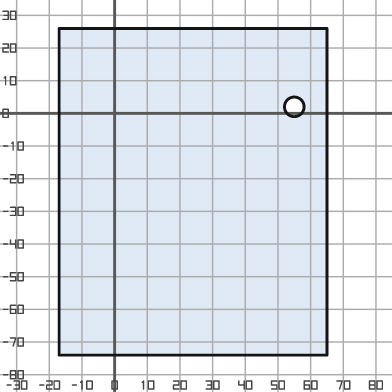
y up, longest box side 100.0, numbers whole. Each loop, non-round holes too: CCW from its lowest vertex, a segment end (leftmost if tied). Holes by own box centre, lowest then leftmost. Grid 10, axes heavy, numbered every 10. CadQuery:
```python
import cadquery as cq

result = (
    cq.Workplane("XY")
    .moveTo(-17.0, -74.0)
    .lineTo(65.0, -74.0)
    .lineTo(65.0, 26.0)
    .lineTo(-17.0, 26.0)
    .close()
    .moveTo(55.0, 2.0)
    .circle(3.0)
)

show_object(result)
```